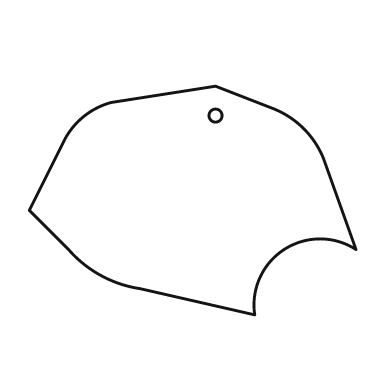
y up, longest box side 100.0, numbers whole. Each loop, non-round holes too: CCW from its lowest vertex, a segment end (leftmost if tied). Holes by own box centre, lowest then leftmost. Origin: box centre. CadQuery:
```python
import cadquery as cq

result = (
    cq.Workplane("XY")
    .moveTo(19.0, -35.0)
    .threePointArc((28.0, -15.0), (50.0, -15.0))
    .lineTo(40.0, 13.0)
    .threePointArc((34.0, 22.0), (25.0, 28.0))
    .lineTo(7.0, 35.0)
    .lineTo(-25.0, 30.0)
    .threePointArc((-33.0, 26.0), (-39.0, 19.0))
    .lineTo(-50.0, -3.0)
    .lineTo(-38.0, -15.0)
    .threePointArc((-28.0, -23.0), (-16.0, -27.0))
    .close()
    .moveTo(7.0, 26.0)
    .circle(2.0)
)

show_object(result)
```